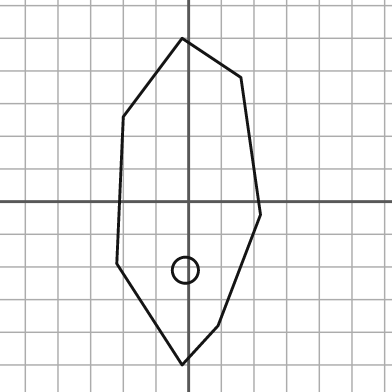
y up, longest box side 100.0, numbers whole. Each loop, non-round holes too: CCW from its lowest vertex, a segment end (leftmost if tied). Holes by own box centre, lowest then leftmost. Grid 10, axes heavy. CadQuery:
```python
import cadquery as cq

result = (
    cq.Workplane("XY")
    .moveTo(-2.0, -50.0)
    .lineTo(9.0, -38.0)
    .lineTo(22.0, -4.0)
    .lineTo(16.0, 38.0)
    .lineTo(-2.0, 50.0)
    .lineTo(-20.0, 26.0)
    .lineTo(-22.0, -19.0)
    .close()
    .moveTo(-1.0, -21.0)
    .circle(4.0)
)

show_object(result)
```